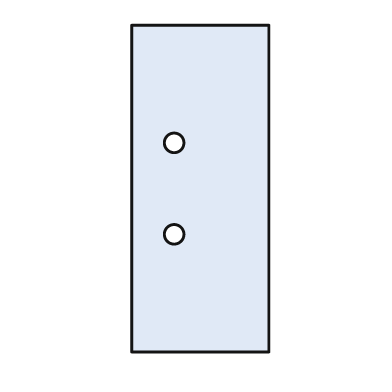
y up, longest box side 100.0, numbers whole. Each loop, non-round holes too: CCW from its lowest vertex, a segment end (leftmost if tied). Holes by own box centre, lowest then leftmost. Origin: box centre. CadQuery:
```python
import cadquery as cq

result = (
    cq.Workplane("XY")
    .moveTo(-21.0, -50.0)
    .lineTo(21.0, -50.0)
    .lineTo(21.0, 50.0)
    .lineTo(-21.0, 50.0)
    .close()
    .moveTo(-8.0, -14.0)
    .circle(3.0)
    .moveTo(-8.0, 14.0)
    .circle(3.0)
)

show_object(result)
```